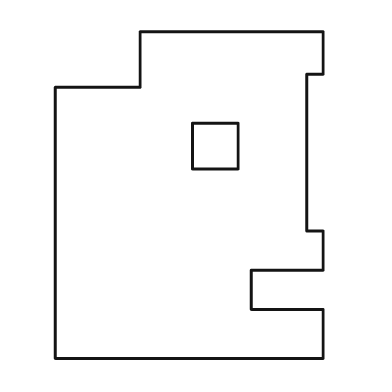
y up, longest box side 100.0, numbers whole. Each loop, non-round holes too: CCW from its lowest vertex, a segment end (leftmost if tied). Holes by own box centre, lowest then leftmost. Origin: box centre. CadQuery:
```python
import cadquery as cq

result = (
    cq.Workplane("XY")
    .moveTo(-41.0, -50.0)
    .lineTo(41.0, -50.0)
    .lineTo(41.0, -35.0)
    .lineTo(19.0, -35.0)
    .lineTo(19.0, -23.0)
    .lineTo(41.0, -23.0)
    .lineTo(41.0, -11.0)
    .lineTo(36.0, -11.0)
    .lineTo(36.0, 37.0)
    .lineTo(41.0, 37.0)
    .lineTo(41.0, 50.0)
    .lineTo(-15.0, 50.0)
    .lineTo(-15.0, 33.0)
    .lineTo(-41.0, 33.0)
    .close()
    .moveTo(1.0, 8.0)
    .lineTo(15.0, 8.0)
    .lineTo(15.0, 22.0)
    .lineTo(1.0, 22.0)
    .close()
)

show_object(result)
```